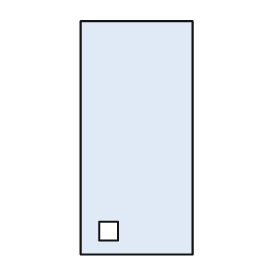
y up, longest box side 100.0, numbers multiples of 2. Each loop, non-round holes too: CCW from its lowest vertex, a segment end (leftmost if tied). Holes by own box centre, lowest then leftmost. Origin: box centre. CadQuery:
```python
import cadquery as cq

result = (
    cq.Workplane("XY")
    .moveTo(-24.0, -50.0)
    .lineTo(24.0, -50.0)
    .lineTo(24.0, 50.0)
    .lineTo(-24.0, 50.0)
    .close()
    .moveTo(-16.0, -44.0)
    .lineTo(-8.0, -44.0)
    .lineTo(-8.0, -36.0)
    .lineTo(-16.0, -36.0)
    .close()
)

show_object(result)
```